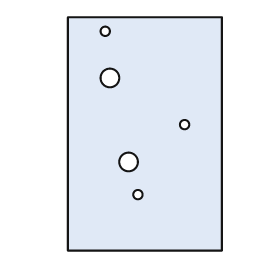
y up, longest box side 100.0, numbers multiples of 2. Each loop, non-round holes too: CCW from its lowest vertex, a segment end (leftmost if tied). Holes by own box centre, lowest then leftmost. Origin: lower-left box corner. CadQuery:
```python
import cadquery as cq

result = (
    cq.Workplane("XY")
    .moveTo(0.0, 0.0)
    .lineTo(66.0, 0.0)
    .lineTo(66.0, 100.0)
    .lineTo(0.0, 100.0)
    .close()
    .moveTo(30.0, 24.0)
    .circle(2.0)
    .moveTo(26.0, 38.0)
    .circle(4.0)
    .moveTo(50.0, 54.0)
    .circle(2.0)
    .moveTo(18.0, 74.0)
    .circle(4.0)
    .moveTo(16.0, 94.0)
    .circle(2.0)
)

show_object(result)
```